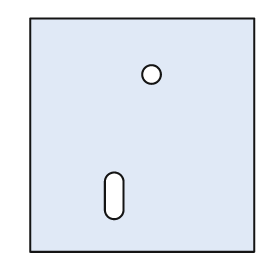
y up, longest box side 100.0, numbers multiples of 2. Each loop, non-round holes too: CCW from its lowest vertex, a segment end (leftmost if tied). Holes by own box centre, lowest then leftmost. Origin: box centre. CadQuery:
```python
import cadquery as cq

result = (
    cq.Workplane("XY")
    .moveTo(-48.0, -50.0)
    .lineTo(48.0, -50.0)
    .lineTo(48.0, 50.0)
    .lineTo(-48.0, 50.0)
    .close()
    .moveTo(-16.0, -32.0)
    .threePointArc((-12.0, -36.0), (-8.0, -32.0))
    .lineTo(-8.0, -20.0)
    .threePointArc((-12.0, -16.0), (-16.0, -20.0))
    .close()
    .moveTo(4.0, 26.0)
    .circle(4.0)
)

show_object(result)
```